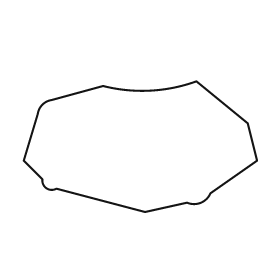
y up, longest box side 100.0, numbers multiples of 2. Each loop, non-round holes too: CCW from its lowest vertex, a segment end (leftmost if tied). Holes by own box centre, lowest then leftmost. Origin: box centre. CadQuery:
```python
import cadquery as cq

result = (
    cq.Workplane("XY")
    .moveTo(2.0, -28.0)
    .lineTo(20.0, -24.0)
    .threePointArc((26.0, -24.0), (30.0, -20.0))
    .lineTo(50.0, -6.0)
    .lineTo(46.0, 10.0)
    .lineTo(24.0, 28.0)
    .threePointArc((4.0, 24.0), (-16.0, 26.0))
    .lineTo(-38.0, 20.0)
    .threePointArc((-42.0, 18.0), (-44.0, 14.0))
    .lineTo(-50.0, -6.0)
    .lineTo(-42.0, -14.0)
    .threePointArc((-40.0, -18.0), (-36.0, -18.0))
    .close()
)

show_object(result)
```